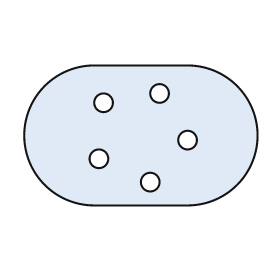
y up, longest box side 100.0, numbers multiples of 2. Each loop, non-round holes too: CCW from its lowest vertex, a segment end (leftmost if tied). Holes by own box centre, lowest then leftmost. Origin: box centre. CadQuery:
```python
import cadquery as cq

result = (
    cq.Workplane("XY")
    .moveTo(-20.0, -30.0)
    .lineTo(20.0, -30.0)
    .threePointArc((50.0, 0.0), (20.0, 30.0))
    .lineTo(-20.0, 30.0)
    .threePointArc((-50.0, 0.0), (-20.0, -30.0))
    .close()
    .moveTo(4.0, -20.0)
    .circle(4.0)
    .moveTo(-18.0, -10.0)
    .circle(4.0)
    .moveTo(20.0, -2.0)
    .circle(4.0)
    .moveTo(-16.0, 14.0)
    .circle(4.0)
    .moveTo(8.0, 18.0)
    .circle(4.0)
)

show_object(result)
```